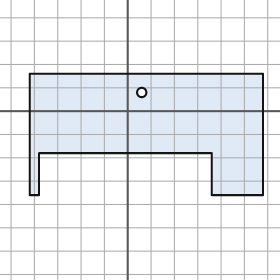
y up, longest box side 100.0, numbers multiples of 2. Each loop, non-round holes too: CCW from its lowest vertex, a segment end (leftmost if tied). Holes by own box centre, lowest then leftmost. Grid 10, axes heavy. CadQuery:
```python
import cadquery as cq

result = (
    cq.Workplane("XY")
    .moveTo(-42.0, -36.0)
    .lineTo(-38.0, -36.0)
    .lineTo(-38.0, -18.0)
    .lineTo(36.0, -18.0)
    .lineTo(36.0, -36.0)
    .lineTo(58.0, -36.0)
    .lineTo(58.0, 16.0)
    .lineTo(-42.0, 16.0)
    .close()
    .moveTo(6.0, 8.0)
    .circle(2.0)
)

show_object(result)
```